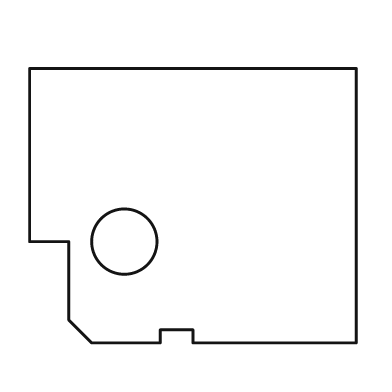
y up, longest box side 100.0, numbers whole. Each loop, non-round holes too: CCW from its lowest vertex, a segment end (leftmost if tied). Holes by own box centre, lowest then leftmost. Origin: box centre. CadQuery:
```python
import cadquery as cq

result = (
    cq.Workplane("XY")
    .moveTo(-31.0, -42.0)
    .lineTo(-10.0, -42.0)
    .lineTo(-10.0, -38.0)
    .lineTo(0.0, -38.0)
    .lineTo(0.0, -42.0)
    .lineTo(50.0, -42.0)
    .lineTo(50.0, 42.0)
    .lineTo(-50.0, 42.0)
    .lineTo(-50.0, -11.0)
    .lineTo(-38.0, -11.0)
    .lineTo(-38.0, -35.0)
    .close()
    .moveTo(-21.0, -11.0)
    .circle(10.0)
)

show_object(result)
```